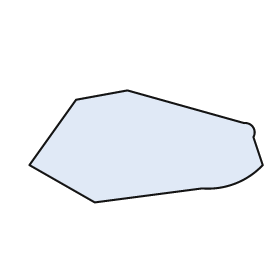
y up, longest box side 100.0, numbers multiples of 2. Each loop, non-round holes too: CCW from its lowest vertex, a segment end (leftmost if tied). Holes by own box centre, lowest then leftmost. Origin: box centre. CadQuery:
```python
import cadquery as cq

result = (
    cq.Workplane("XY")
    .moveTo(-22.0, -24.0)
    .lineTo(24.0, -18.0)
    .threePointArc((38.0, -16.0), (50.0, -8.0))
    .lineTo(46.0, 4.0)
    .threePointArc((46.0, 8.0), (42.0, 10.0))
    .lineTo(-8.0, 24.0)
    .lineTo(-30.0, 20.0)
    .lineTo(-50.0, -8.0)
    .close()
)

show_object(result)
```